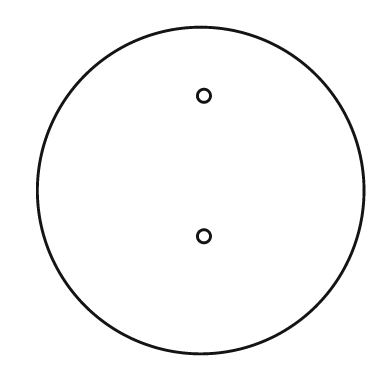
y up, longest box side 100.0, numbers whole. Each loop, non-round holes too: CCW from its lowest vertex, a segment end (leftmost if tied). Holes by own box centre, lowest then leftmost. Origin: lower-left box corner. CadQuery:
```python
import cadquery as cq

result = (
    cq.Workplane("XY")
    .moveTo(50.0, 50.0)
    .circle(50.0)
    .moveTo(51.0, 36.0)
    .circle(2.0)
    .moveTo(51.0, 79.0)
    .circle(2.0)
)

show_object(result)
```